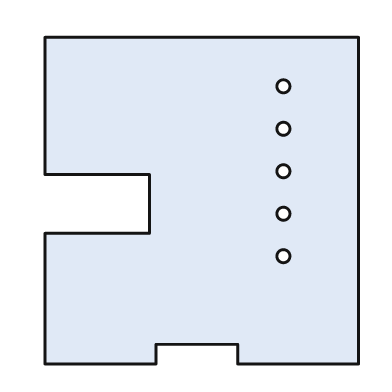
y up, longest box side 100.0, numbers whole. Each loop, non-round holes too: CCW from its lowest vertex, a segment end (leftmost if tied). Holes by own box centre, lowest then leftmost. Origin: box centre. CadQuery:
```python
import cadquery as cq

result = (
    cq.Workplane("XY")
    .moveTo(-48.0, -50.0)
    .lineTo(-14.0, -50.0)
    .lineTo(-14.0, -44.0)
    .lineTo(11.0, -44.0)
    .lineTo(11.0, -50.0)
    .lineTo(48.0, -50.0)
    .lineTo(48.0, 50.0)
    .lineTo(-48.0, 50.0)
    .lineTo(-48.0, 8.0)
    .lineTo(-16.0, 8.0)
    .lineTo(-16.0, -10.0)
    .lineTo(-48.0, -10.0)
    .close()
    .moveTo(25.0, -17.0)
    .circle(2.0)
    .moveTo(25.0, -4.0)
    .circle(2.0)
    .moveTo(25.0, 9.0)
    .circle(2.0)
    .moveTo(25.0, 22.0)
    .circle(2.0)
    .moveTo(25.0, 35.0)
    .circle(2.0)
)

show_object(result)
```